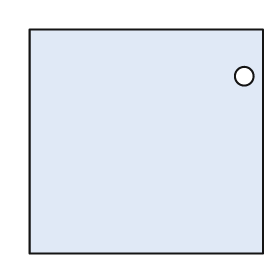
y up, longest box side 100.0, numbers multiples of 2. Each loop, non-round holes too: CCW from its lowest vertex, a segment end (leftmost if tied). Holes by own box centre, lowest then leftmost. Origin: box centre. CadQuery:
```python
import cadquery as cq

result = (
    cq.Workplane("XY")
    .moveTo(-50.0, -48.0)
    .lineTo(50.0, -48.0)
    .lineTo(50.0, 48.0)
    .lineTo(-50.0, 48.0)
    .close()
    .moveTo(42.0, 28.0)
    .circle(4.0)
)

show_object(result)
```